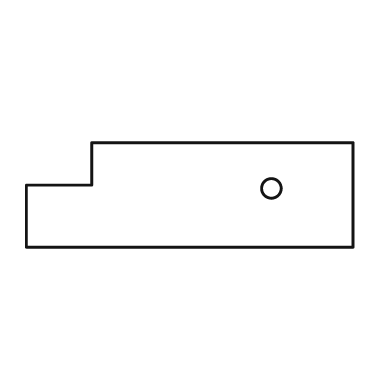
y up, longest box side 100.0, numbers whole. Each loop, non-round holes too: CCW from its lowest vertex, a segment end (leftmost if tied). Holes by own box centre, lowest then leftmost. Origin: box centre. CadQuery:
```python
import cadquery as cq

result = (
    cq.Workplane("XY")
    .moveTo(-50.0, -16.0)
    .lineTo(50.0, -16.0)
    .lineTo(50.0, 16.0)
    .lineTo(-30.0, 16.0)
    .lineTo(-30.0, 3.0)
    .lineTo(-50.0, 3.0)
    .close()
    .moveTo(25.0, 2.0)
    .circle(3.0)
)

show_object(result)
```